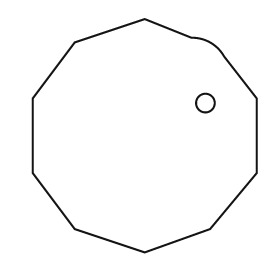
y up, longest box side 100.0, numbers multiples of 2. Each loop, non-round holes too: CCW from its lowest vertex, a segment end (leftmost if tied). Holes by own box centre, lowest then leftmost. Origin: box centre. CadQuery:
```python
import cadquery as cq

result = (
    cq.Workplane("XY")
    .moveTo(0.0, -50.0)
    .lineTo(28.0, -40.0)
    .lineTo(48.0, -16.0)
    .lineTo(48.0, 16.0)
    .lineTo(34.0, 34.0)
    .threePointArc((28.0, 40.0), (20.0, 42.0))
    .lineTo(0.0, 50.0)
    .lineTo(-30.0, 40.0)
    .lineTo(-48.0, 16.0)
    .lineTo(-48.0, -16.0)
    .lineTo(-30.0, -40.0)
    .close()
    .moveTo(26.0, 14.0)
    .circle(4.0)
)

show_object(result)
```